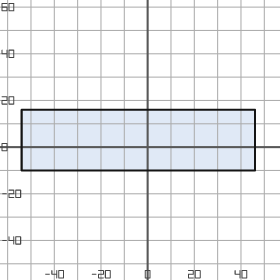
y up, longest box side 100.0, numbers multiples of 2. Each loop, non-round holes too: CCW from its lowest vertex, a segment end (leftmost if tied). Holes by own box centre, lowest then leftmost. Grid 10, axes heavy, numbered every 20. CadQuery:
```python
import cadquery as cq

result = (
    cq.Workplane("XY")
    .moveTo(-54.0, -10.0)
    .lineTo(46.0, -10.0)
    .lineTo(46.0, 16.0)
    .lineTo(-54.0, 16.0)
    .close()
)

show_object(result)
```